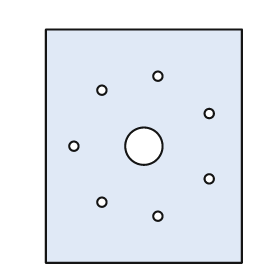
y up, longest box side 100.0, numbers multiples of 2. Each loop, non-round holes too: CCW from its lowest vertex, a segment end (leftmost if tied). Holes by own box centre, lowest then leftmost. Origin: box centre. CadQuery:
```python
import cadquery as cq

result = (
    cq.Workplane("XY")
    .moveTo(-42.0, -50.0)
    .lineTo(42.0, -50.0)
    .lineTo(42.0, 50.0)
    .lineTo(-42.0, 50.0)
    .close()
    .moveTo(6.0, -30.0)
    .circle(2.0)
    .moveTo(-18.0, -24.0)
    .circle(2.0)
    .moveTo(28.0, -14.0)
    .circle(2.0)
    .moveTo(-30.0, 0.0)
    .circle(2.0)
    .moveTo(0.0, 0.0)
    .circle(8.0)
    .moveTo(28.0, 14.0)
    .circle(2.0)
    .moveTo(-18.0, 24.0)
    .circle(2.0)
    .moveTo(6.0, 30.0)
    .circle(2.0)
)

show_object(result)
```